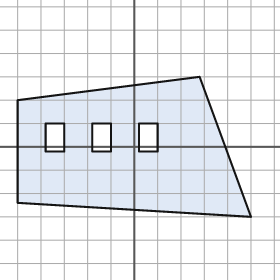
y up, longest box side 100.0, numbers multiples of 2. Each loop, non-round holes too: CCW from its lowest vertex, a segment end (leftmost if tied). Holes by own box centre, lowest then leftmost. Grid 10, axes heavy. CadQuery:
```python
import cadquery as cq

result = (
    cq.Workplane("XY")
    .moveTo(50.0, -30.0)
    .lineTo(28.0, 30.0)
    .lineTo(-50.0, 20.0)
    .lineTo(-50.0, -24.0)
    .close()
    .moveTo(-38.0, -2.0)
    .lineTo(-30.0, -2.0)
    .lineTo(-30.0, 10.0)
    .lineTo(-38.0, 10.0)
    .close()
    .moveTo(-18.0, -2.0)
    .lineTo(-10.0, -2.0)
    .lineTo(-10.0, 10.0)
    .lineTo(-18.0, 10.0)
    .close()
    .moveTo(2.0, -2.0)
    .lineTo(10.0, -2.0)
    .lineTo(10.0, 10.0)
    .lineTo(2.0, 10.0)
    .close()
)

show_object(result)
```